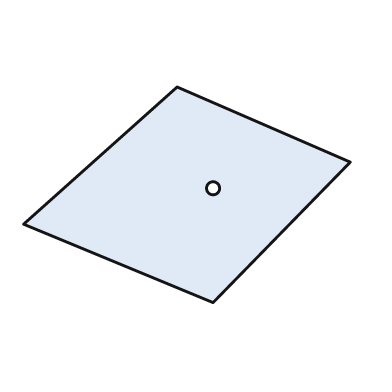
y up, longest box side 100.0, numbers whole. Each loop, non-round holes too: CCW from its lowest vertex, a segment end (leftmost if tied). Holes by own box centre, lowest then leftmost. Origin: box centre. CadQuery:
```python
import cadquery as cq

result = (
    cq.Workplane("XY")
    .moveTo(8.0, -33.0)
    .lineTo(50.0, 10.0)
    .lineTo(-3.0, 33.0)
    .lineTo(-50.0, -9.0)
    .close()
    .moveTo(8.0, 2.0)
    .circle(2.0)
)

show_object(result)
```